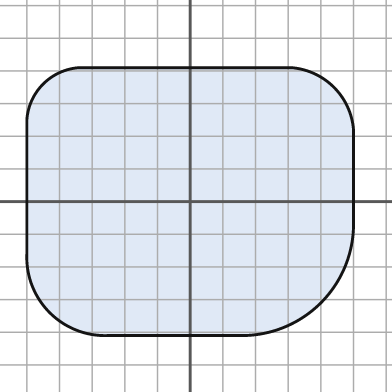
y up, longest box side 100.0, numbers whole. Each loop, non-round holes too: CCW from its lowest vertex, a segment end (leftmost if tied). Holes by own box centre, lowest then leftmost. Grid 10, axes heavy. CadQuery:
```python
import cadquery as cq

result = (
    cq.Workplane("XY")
    .moveTo(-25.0, -41.0)
    .lineTo(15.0, -41.0)
    .threePointArc((40.0, -31.0), (50.0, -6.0))
    .lineTo(50.0, 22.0)
    .threePointArc((44.0, 35.0), (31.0, 41.0))
    .lineTo(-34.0, 41.0)
    .threePointArc((-45.0, 36.0), (-50.0, 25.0))
    .lineTo(-50.0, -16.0)
    .threePointArc((-43.0, -34.0), (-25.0, -41.0))
    .close()
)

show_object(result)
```